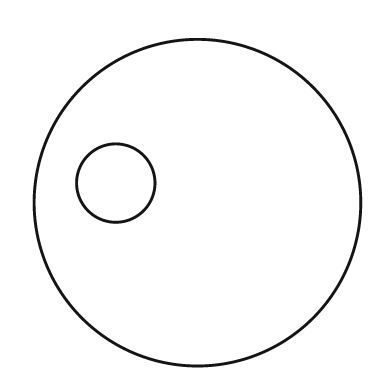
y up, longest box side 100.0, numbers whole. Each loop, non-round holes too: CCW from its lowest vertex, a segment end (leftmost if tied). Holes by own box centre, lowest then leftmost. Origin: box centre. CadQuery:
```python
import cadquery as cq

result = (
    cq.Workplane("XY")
    .moveTo(0.0, 0.0)
    .circle(50.0)
    .moveTo(-25.0, 6.0)
    .circle(12.0)
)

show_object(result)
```